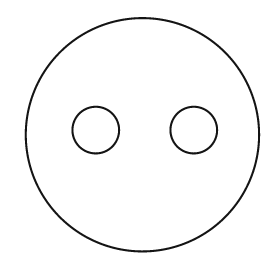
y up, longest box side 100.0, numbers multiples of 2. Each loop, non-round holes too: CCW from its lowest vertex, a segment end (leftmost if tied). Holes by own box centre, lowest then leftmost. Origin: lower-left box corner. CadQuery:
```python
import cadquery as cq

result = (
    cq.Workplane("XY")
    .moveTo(50.0, 50.0)
    .circle(50.0)
    .moveTo(30.0, 52.0)
    .circle(10.0)
    .moveTo(72.0, 52.0)
    .circle(10.0)
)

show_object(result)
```